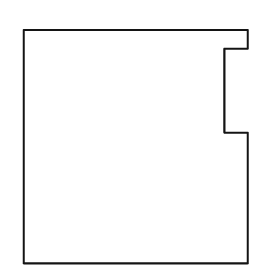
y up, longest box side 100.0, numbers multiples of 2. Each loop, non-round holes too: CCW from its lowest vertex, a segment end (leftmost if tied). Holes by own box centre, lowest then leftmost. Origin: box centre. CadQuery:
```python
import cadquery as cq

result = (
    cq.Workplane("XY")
    .moveTo(-48.0, -50.0)
    .lineTo(48.0, -50.0)
    .lineTo(48.0, 6.0)
    .lineTo(38.0, 6.0)
    .lineTo(38.0, 42.0)
    .lineTo(48.0, 42.0)
    .lineTo(48.0, 50.0)
    .lineTo(-48.0, 50.0)
    .close()
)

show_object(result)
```